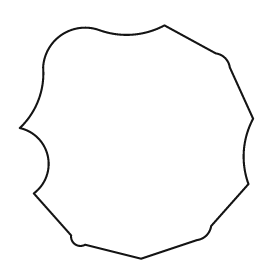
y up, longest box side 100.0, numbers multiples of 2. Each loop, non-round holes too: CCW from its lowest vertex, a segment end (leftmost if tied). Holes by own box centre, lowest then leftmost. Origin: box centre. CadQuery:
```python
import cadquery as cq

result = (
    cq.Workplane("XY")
    .moveTo(2.0, -50.0)
    .lineTo(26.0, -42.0)
    .threePointArc((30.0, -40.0), (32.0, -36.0))
    .lineTo(48.0, -18.0)
    .threePointArc((46.0, -4.0), (50.0, 10.0))
    .lineTo(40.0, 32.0)
    .threePointArc((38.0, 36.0), (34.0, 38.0))
    .lineTo(12.0, 50.0)
    .threePointArc((-2.0, 46.0), (-16.0, 48.0))
    .threePointArc((-32.0, 46.0), (-40.0, 32.0))
    .threePointArc((-42.0, 18.0), (-50.0, 6.0))
    .threePointArc((-38.0, -6.0), (-44.0, -22.0))
    .lineTo(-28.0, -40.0)
    .threePointArc((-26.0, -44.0), (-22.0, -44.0))
    .close()
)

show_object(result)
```